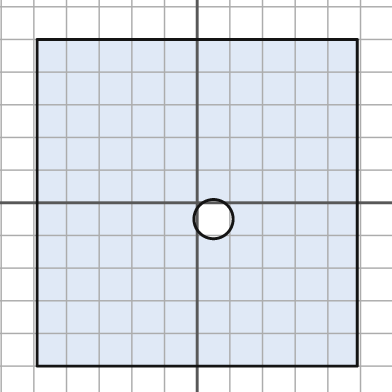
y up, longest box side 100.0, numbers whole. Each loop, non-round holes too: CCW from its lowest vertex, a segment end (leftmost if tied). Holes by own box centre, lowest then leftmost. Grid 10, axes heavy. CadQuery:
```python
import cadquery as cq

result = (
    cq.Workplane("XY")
    .moveTo(-49.0, -50.0)
    .lineTo(49.0, -50.0)
    .lineTo(49.0, 50.0)
    .lineTo(-49.0, 50.0)
    .close()
    .moveTo(5.0, -5.0)
    .circle(6.0)
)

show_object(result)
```